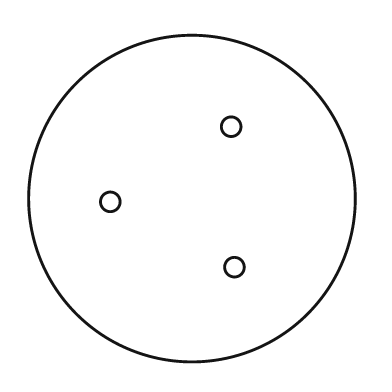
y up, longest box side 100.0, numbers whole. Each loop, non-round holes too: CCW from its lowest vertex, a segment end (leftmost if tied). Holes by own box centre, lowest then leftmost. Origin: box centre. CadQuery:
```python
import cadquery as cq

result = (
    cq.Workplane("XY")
    .moveTo(0.0, 0.0)
    .circle(50.0)
    .moveTo(13.0, -21.0)
    .circle(3.0)
    .moveTo(-25.0, -1.0)
    .circle(3.0)
    .moveTo(12.0, 22.0)
    .circle(3.0)
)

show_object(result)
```